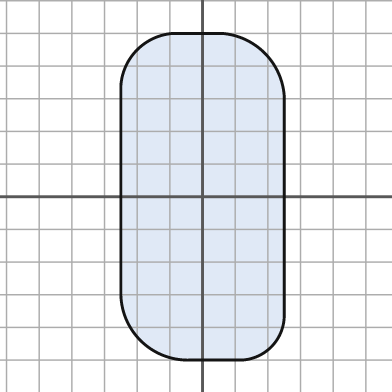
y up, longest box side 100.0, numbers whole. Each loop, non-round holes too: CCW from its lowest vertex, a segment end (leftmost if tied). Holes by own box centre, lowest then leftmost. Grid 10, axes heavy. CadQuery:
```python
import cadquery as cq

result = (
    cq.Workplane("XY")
    .moveTo(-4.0, -50.0)
    .lineTo(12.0, -50.0)
    .threePointArc((21.0, -46.0), (25.0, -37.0))
    .lineTo(25.0, 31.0)
    .threePointArc((19.0, 44.0), (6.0, 50.0))
    .lineTo(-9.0, 50.0)
    .threePointArc((-20.0, 45.0), (-25.0, 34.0))
    .lineTo(-25.0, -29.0)
    .threePointArc((-19.0, -44.0), (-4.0, -50.0))
    .close()
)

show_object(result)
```